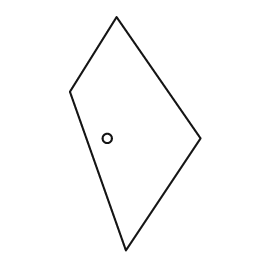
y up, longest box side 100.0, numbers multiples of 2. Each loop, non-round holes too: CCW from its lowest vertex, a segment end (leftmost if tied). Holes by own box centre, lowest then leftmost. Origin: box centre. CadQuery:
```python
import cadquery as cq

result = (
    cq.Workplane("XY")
    .moveTo(-4.0, -50.0)
    .lineTo(28.0, -2.0)
    .lineTo(-8.0, 50.0)
    .lineTo(-28.0, 18.0)
    .close()
    .moveTo(-12.0, -2.0)
    .circle(2.0)
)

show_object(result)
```